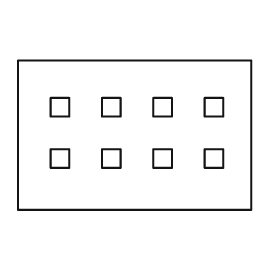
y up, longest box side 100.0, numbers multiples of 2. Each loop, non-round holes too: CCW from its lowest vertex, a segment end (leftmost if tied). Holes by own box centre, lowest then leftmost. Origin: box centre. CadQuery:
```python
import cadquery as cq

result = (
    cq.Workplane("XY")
    .moveTo(-50.0, -32.0)
    .lineTo(50.0, -32.0)
    .lineTo(50.0, 32.0)
    .lineTo(-50.0, 32.0)
    .close()
    .moveTo(-36.0, -14.0)
    .lineTo(-28.0, -14.0)
    .lineTo(-28.0, -6.0)
    .lineTo(-36.0, -6.0)
    .close()
    .moveTo(-14.0, -14.0)
    .lineTo(-6.0, -14.0)
    .lineTo(-6.0, -6.0)
    .lineTo(-14.0, -6.0)
    .close()
    .moveTo(8.0, -14.0)
    .lineTo(16.0, -14.0)
    .lineTo(16.0, -6.0)
    .lineTo(8.0, -6.0)
    .close()
    .moveTo(30.0, -14.0)
    .lineTo(38.0, -14.0)
    .lineTo(38.0, -6.0)
    .lineTo(30.0, -6.0)
    .close()
    .moveTo(-36.0, 8.0)
    .lineTo(-28.0, 8.0)
    .lineTo(-28.0, 16.0)
    .lineTo(-36.0, 16.0)
    .close()
    .moveTo(-14.0, 8.0)
    .lineTo(-6.0, 8.0)
    .lineTo(-6.0, 16.0)
    .lineTo(-14.0, 16.0)
    .close()
    .moveTo(8.0, 8.0)
    .lineTo(16.0, 8.0)
    .lineTo(16.0, 16.0)
    .lineTo(8.0, 16.0)
    .close()
    .moveTo(30.0, 8.0)
    .lineTo(38.0, 8.0)
    .lineTo(38.0, 16.0)
    .lineTo(30.0, 16.0)
    .close()
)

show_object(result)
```